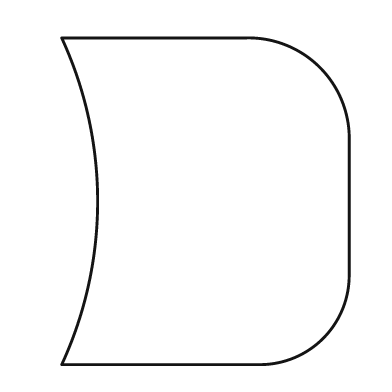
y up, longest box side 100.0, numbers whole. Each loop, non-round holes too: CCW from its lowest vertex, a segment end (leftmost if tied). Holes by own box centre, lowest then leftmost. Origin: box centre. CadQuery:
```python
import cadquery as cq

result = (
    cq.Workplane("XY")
    .moveTo(-44.0, -50.0)
    .lineTo(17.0, -50.0)
    .threePointArc((36.0, -42.0), (44.0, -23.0))
    .lineTo(44.0, 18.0)
    .threePointArc((35.0, 41.0), (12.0, 50.0))
    .lineTo(-44.0, 50.0)
    .threePointArc((-33.0, 0.0), (-44.0, -50.0))
    .close()
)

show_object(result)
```